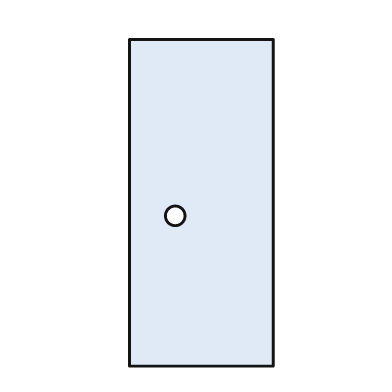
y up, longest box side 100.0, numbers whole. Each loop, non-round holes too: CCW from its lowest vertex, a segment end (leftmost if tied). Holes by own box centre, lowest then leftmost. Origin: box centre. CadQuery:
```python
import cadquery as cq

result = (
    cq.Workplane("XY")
    .moveTo(-22.0, -50.0)
    .lineTo(22.0, -50.0)
    .lineTo(22.0, 50.0)
    .lineTo(-22.0, 50.0)
    .close()
    .moveTo(-8.0, -4.0)
    .circle(3.0)
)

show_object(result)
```